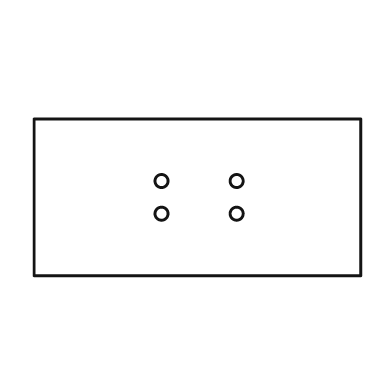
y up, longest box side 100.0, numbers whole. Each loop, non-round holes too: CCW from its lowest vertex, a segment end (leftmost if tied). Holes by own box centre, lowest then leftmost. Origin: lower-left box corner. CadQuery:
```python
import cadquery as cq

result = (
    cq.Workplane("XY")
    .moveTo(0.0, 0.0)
    .lineTo(100.0, 0.0)
    .lineTo(100.0, 48.0)
    .lineTo(0.0, 48.0)
    .close()
    .moveTo(39.0, 19.0)
    .circle(2.0)
    .moveTo(62.0, 19.0)
    .circle(2.0)
    .moveTo(39.0, 29.0)
    .circle(2.0)
    .moveTo(62.0, 29.0)
    .circle(2.0)
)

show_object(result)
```